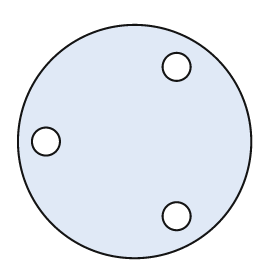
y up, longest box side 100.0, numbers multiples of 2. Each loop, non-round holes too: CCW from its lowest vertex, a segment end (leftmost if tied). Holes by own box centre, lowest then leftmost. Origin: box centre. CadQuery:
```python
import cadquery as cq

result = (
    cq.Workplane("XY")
    .moveTo(0.0, 0.0)
    .circle(50.0)
    .moveTo(18.0, -32.0)
    .circle(6.0)
    .moveTo(-38.0, 0.0)
    .circle(6.0)
    .moveTo(18.0, 32.0)
    .circle(6.0)
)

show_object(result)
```